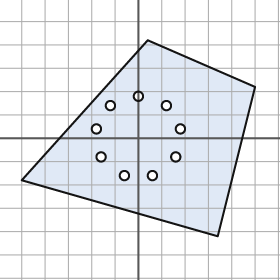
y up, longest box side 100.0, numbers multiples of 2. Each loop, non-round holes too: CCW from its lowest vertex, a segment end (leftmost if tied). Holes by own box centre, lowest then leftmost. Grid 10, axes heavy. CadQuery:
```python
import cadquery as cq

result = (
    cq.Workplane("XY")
    .moveTo(34.0, -42.0)
    .lineTo(50.0, 22.0)
    .lineTo(4.0, 42.0)
    .lineTo(-50.0, -18.0)
    .close()
    .moveTo(-6.0, -16.0)
    .circle(2.0)
    .moveTo(6.0, -16.0)
    .circle(2.0)
    .moveTo(-16.0, -8.0)
    .circle(2.0)
    .moveTo(16.0, -8.0)
    .circle(2.0)
    .moveTo(-18.0, 4.0)
    .circle(2.0)
    .moveTo(18.0, 4.0)
    .circle(2.0)
    .moveTo(-12.0, 14.0)
    .circle(2.0)
    .moveTo(12.0, 14.0)
    .circle(2.0)
    .moveTo(0.0, 18.0)
    .circle(2.0)
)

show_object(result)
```